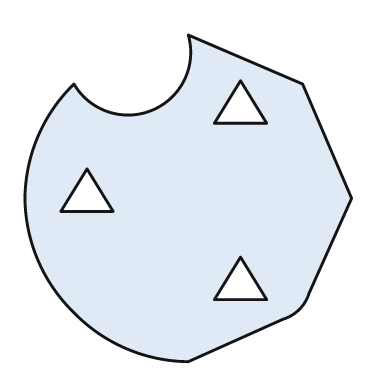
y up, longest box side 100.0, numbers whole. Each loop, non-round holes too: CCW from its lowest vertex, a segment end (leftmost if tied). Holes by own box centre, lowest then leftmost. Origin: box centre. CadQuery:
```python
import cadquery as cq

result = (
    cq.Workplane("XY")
    .moveTo(0.0, -50.0)
    .lineTo(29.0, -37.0)
    .threePointArc((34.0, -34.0), (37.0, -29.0))
    .lineTo(50.0, 0.0)
    .lineTo(35.0, 35.0)
    .lineTo(0.0, 50.0)
    .threePointArc((-11.0, 27.0), (-35.0, 35.0))
    .threePointArc((-46.0, 19.0), (-50.0, 0.0))
    .threePointArc((-46.0, -19.0), (-35.0, -35.0))
    .threePointArc((-19.0, -46.0), (0.0, -50.0))
    .close()
    .moveTo(8.0, -31.0)
    .lineTo(24.0, -31.0)
    .lineTo(16.0, -18.0)
    .close()
    .moveTo(-39.0, -4.0)
    .lineTo(-23.0, -4.0)
    .lineTo(-31.0, 9.0)
    .close()
    .moveTo(8.0, 23.0)
    .lineTo(24.0, 23.0)
    .lineTo(16.0, 36.0)
    .close()
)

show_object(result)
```